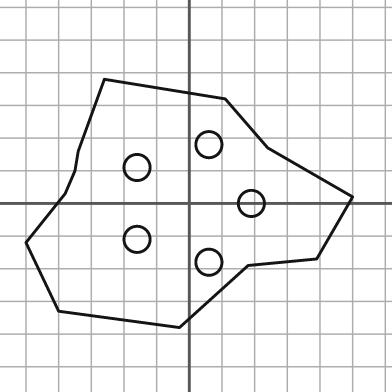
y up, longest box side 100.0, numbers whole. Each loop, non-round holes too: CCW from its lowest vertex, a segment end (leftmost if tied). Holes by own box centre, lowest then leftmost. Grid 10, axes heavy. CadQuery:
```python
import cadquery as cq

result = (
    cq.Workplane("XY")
    .moveTo(-3.0, -38.0)
    .lineTo(18.0, -19.0)
    .lineTo(39.0, -17.0)
    .lineTo(50.0, 2.0)
    .lineTo(24.0, 17.0)
    .lineTo(11.0, 32.0)
    .lineTo(-26.0, 38.0)
    .lineTo(-34.0, 16.0)
    .lineTo(-35.0, 10.0)
    .lineTo(-38.0, 3.0)
    .lineTo(-50.0, -12.0)
    .lineTo(-40.0, -33.0)
    .close()
    .moveTo(6.0, -18.0)
    .circle(4.0)
    .moveTo(-16.0, -11.0)
    .circle(4.0)
    .moveTo(19.0, 0.0)
    .circle(4.0)
    .moveTo(-16.0, 11.0)
    .circle(4.0)
    .moveTo(6.0, 18.0)
    .circle(4.0)
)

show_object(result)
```